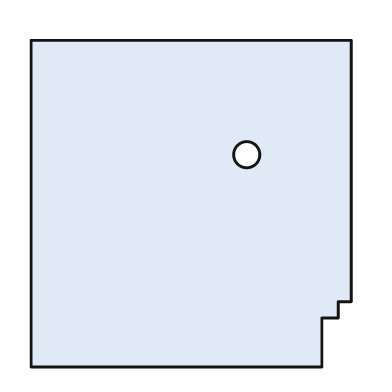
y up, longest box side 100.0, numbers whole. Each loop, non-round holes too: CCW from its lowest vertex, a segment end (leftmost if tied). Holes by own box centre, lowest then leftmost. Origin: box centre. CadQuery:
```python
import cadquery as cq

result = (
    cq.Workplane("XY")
    .moveTo(-49.0, -50.0)
    .lineTo(40.0, -50.0)
    .lineTo(40.0, -35.0)
    .lineTo(45.0, -35.0)
    .lineTo(45.0, -30.0)
    .lineTo(49.0, -30.0)
    .lineTo(49.0, 50.0)
    .lineTo(-49.0, 50.0)
    .close()
    .moveTo(17.0, 15.0)
    .circle(4.0)
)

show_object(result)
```